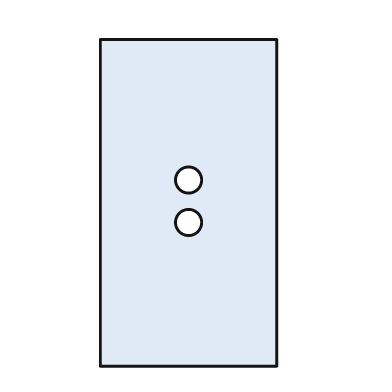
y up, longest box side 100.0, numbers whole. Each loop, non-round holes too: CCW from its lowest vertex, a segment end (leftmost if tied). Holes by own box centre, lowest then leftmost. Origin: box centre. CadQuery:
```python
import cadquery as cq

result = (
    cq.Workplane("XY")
    .moveTo(-27.0, -50.0)
    .lineTo(27.0, -50.0)
    .lineTo(27.0, 50.0)
    .lineTo(-27.0, 50.0)
    .close()
    .moveTo(0.0, -6.0)
    .circle(4.0)
    .moveTo(0.0, 7.0)
    .circle(4.0)
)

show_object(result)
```